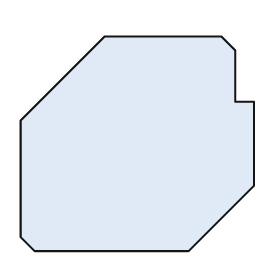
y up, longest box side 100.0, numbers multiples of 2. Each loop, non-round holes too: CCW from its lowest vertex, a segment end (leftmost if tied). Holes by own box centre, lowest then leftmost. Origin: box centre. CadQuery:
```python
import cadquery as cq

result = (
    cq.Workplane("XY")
    .moveTo(-44.0, -46.0)
    .lineTo(22.0, -46.0)
    .lineTo(50.0, -18.0)
    .lineTo(50.0, 18.0)
    .lineTo(42.0, 18.0)
    .lineTo(42.0, 40.0)
    .lineTo(36.0, 46.0)
    .lineTo(-14.0, 46.0)
    .lineTo(-50.0, 10.0)
    .lineTo(-50.0, -40.0)
    .close()
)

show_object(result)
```